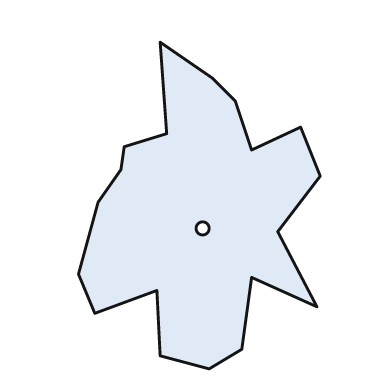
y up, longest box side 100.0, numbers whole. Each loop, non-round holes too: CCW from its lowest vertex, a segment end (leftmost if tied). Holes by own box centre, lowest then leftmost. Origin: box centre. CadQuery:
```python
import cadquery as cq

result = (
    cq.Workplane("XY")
    .moveTo(3.0, -50.0)
    .lineTo(13.0, -44.0)
    .lineTo(16.0, -22.0)
    .lineTo(36.0, -31.0)
    .lineTo(24.0, -8.0)
    .lineTo(37.0, 9.0)
    .lineTo(31.0, 24.0)
    .lineTo(16.0, 17.0)
    .lineTo(11.0, 32.0)
    .lineTo(4.0, 39.0)
    .lineTo(-12.0, 50.0)
    .lineTo(-10.0, 22.0)
    .lineTo(-23.0, 18.0)
    .lineTo(-24.0, 11.0)
    .lineTo(-31.0, 1.0)
    .lineTo(-37.0, -21.0)
    .lineTo(-32.0, -33.0)
    .lineTo(-13.0, -26.0)
    .lineTo(-12.0, -46.0)
    .close()
    .moveTo(1.0, -7.0)
    .circle(2.0)
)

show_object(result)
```